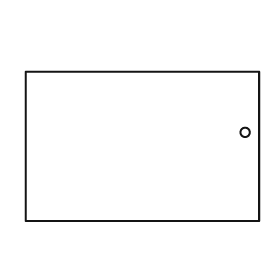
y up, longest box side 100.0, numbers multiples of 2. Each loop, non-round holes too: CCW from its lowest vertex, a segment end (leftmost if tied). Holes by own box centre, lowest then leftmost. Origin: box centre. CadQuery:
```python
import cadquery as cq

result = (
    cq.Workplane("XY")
    .moveTo(-50.0, -32.0)
    .lineTo(50.0, -32.0)
    .lineTo(50.0, 32.0)
    .lineTo(-50.0, 32.0)
    .close()
    .moveTo(44.0, 6.0)
    .circle(2.0)
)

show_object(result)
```